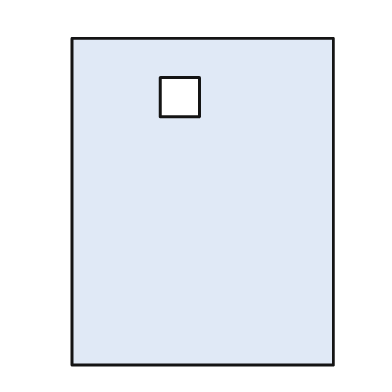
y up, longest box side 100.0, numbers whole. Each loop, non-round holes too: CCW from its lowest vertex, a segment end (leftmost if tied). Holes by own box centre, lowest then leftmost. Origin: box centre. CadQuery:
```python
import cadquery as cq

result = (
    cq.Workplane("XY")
    .moveTo(-40.0, -50.0)
    .lineTo(40.0, -50.0)
    .lineTo(40.0, 50.0)
    .lineTo(-40.0, 50.0)
    .close()
    .moveTo(-13.0, 26.0)
    .lineTo(-1.0, 26.0)
    .lineTo(-1.0, 38.0)
    .lineTo(-13.0, 38.0)
    .close()
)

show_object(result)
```